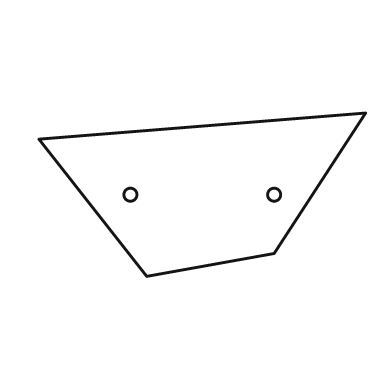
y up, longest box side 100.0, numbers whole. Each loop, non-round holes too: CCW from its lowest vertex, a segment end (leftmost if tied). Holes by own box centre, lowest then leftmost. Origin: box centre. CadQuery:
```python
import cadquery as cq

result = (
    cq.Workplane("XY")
    .moveTo(-17.0, -25.0)
    .lineTo(22.0, -18.0)
    .lineTo(50.0, 25.0)
    .lineTo(-50.0, 17.0)
    .close()
    .moveTo(-22.0, 0.0)
    .circle(2.0)
    .moveTo(22.0, 0.0)
    .circle(2.0)
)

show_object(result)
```